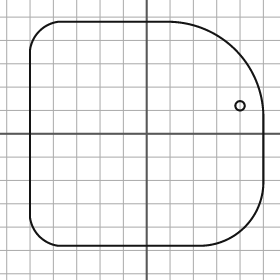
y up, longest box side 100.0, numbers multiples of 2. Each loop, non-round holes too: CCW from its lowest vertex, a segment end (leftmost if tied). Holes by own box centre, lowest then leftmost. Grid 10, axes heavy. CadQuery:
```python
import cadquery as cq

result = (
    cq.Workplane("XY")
    .moveTo(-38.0, -48.0)
    .lineTo(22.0, -48.0)
    .threePointArc((42.0, -40.0), (50.0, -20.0))
    .lineTo(50.0, 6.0)
    .threePointArc((38.0, 36.0), (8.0, 48.0))
    .lineTo(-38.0, 48.0)
    .threePointArc((-46.0, 44.0), (-50.0, 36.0))
    .lineTo(-50.0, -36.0)
    .threePointArc((-46.0, -44.0), (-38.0, -48.0))
    .close()
    .moveTo(40.0, 12.0)
    .circle(2.0)
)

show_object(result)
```